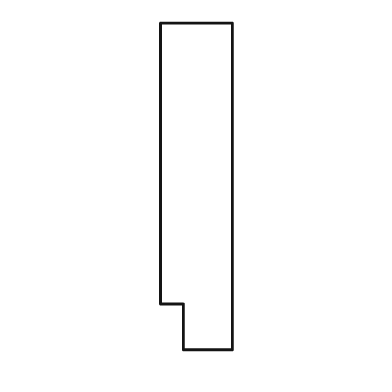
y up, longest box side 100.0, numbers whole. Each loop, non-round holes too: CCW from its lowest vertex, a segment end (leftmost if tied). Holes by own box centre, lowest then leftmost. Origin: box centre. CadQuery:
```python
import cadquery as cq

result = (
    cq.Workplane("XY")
    .moveTo(-4.0, -50.0)
    .lineTo(11.0, -50.0)
    .lineTo(11.0, 50.0)
    .lineTo(-11.0, 50.0)
    .lineTo(-11.0, -36.0)
    .lineTo(-4.0, -36.0)
    .close()
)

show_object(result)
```